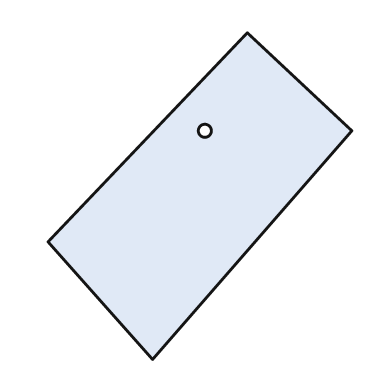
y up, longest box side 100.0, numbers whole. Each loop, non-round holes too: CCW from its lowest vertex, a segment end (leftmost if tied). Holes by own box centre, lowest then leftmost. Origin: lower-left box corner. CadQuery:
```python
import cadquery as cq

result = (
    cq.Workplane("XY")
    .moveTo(32.0, 0.0)
    .lineTo(93.0, 70.0)
    .lineTo(61.0, 100.0)
    .lineTo(0.0, 36.0)
    .close()
    .moveTo(48.0, 70.0)
    .circle(2.0)
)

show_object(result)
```